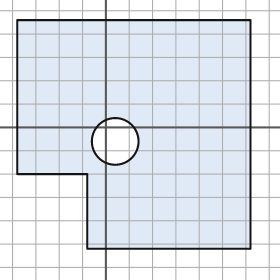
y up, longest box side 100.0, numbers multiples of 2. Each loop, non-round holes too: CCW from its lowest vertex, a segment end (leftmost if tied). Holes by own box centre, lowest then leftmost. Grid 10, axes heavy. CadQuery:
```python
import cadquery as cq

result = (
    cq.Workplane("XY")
    .moveTo(-8.0, -52.0)
    .lineTo(62.0, -52.0)
    .lineTo(62.0, 46.0)
    .lineTo(-38.0, 46.0)
    .lineTo(-38.0, -20.0)
    .lineTo(-8.0, -20.0)
    .close()
    .moveTo(4.0, -6.0)
    .circle(10.0)
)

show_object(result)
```